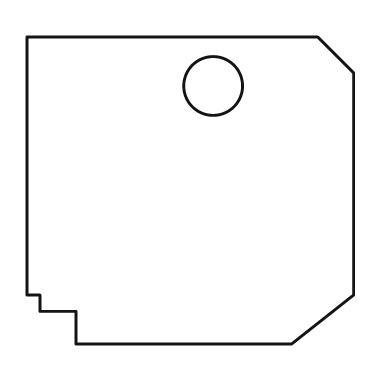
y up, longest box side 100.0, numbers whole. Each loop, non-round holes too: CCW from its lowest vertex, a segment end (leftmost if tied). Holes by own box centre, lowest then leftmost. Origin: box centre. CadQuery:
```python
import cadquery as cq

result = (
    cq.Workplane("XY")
    .moveTo(-35.0, -47.0)
    .lineTo(31.0, -47.0)
    .lineTo(50.0, -32.0)
    .lineTo(50.0, 36.0)
    .lineTo(39.0, 47.0)
    .lineTo(-50.0, 47.0)
    .lineTo(-50.0, -32.0)
    .lineTo(-46.0, -32.0)
    .lineTo(-46.0, -37.0)
    .lineTo(-35.0, -37.0)
    .close()
    .moveTo(7.0, 32.0)
    .circle(9.0)
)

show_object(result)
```